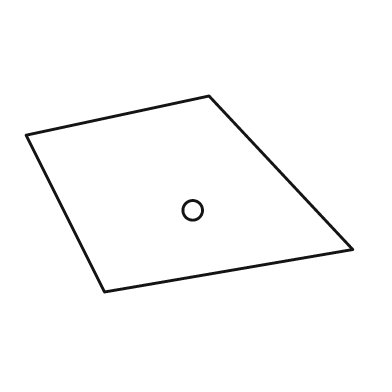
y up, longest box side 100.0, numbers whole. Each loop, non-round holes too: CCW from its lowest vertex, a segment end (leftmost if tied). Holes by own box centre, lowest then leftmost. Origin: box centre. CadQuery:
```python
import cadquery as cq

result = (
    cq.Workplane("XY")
    .moveTo(-26.0, -30.0)
    .lineTo(50.0, -17.0)
    .lineTo(6.0, 30.0)
    .lineTo(-50.0, 18.0)
    .close()
    .moveTo(1.0, -5.0)
    .circle(3.0)
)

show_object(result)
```